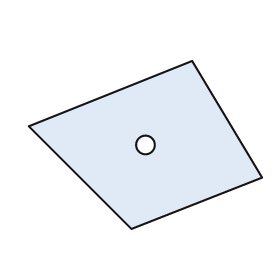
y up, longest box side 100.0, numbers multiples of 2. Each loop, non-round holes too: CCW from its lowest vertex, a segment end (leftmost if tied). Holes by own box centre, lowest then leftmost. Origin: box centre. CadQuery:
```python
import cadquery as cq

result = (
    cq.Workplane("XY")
    .moveTo(-6.0, -36.0)
    .lineTo(50.0, -14.0)
    .lineTo(20.0, 36.0)
    .lineTo(-50.0, 8.0)
    .close()
    .moveTo(0.0, 0.0)
    .circle(4.0)
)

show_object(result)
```